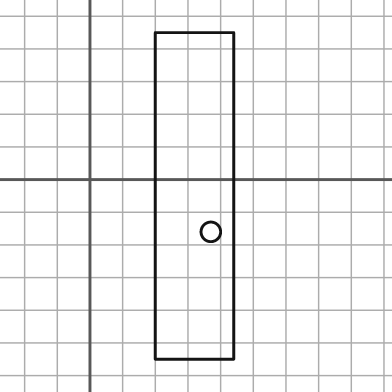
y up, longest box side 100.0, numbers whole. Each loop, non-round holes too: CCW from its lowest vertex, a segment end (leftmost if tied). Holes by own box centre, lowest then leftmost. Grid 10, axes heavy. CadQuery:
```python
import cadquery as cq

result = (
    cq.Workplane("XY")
    .moveTo(20.0, -55.0)
    .lineTo(44.0, -55.0)
    .lineTo(44.0, 45.0)
    .lineTo(20.0, 45.0)
    .close()
    .moveTo(37.0, -16.0)
    .circle(3.0)
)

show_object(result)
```